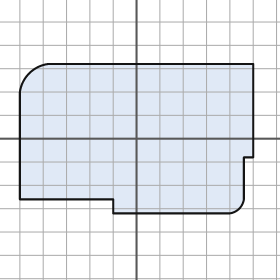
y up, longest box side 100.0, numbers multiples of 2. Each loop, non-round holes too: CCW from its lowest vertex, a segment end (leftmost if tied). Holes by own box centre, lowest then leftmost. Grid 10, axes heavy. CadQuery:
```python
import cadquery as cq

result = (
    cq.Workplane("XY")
    .moveTo(-10.0, -32.0)
    .lineTo(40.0, -32.0)
    .threePointArc((44.0, -30.0), (46.0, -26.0))
    .lineTo(46.0, -8.0)
    .lineTo(50.0, -8.0)
    .lineTo(50.0, 32.0)
    .lineTo(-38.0, 32.0)
    .threePointArc((-46.0, 28.0), (-50.0, 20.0))
    .lineTo(-50.0, -26.0)
    .lineTo(-10.0, -26.0)
    .close()
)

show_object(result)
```